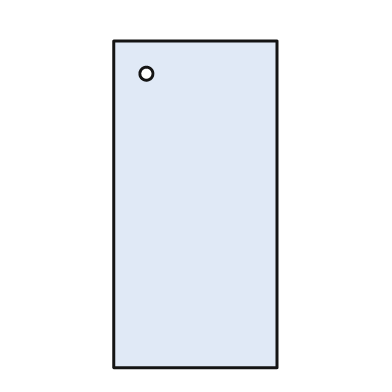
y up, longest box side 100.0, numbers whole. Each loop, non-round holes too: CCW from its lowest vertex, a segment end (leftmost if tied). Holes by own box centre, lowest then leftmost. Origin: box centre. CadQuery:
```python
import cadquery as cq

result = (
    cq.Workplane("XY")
    .moveTo(-25.0, -50.0)
    .lineTo(25.0, -50.0)
    .lineTo(25.0, 50.0)
    .lineTo(-25.0, 50.0)
    .close()
    .moveTo(-15.0, 40.0)
    .circle(2.0)
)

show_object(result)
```